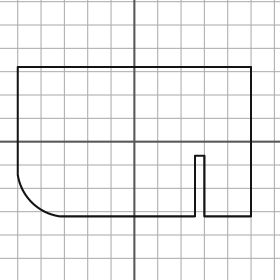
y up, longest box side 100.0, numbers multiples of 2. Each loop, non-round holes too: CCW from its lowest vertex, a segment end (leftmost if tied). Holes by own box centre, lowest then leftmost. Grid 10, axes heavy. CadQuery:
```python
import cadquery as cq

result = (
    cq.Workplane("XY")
    .moveTo(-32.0, -32.0)
    .lineTo(26.0, -32.0)
    .lineTo(26.0, -6.0)
    .lineTo(30.0, -6.0)
    .lineTo(30.0, -32.0)
    .lineTo(50.0, -32.0)
    .lineTo(50.0, 32.0)
    .lineTo(-50.0, 32.0)
    .lineTo(-50.0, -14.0)
    .threePointArc((-44.0, -26.0), (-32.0, -32.0))
    .close()
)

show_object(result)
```